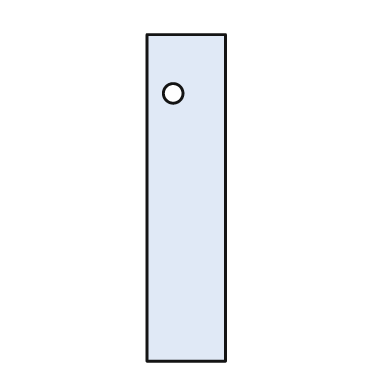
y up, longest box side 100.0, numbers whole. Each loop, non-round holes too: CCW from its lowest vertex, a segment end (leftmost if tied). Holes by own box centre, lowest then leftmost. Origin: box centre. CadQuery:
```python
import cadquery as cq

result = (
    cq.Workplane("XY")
    .moveTo(-12.0, -50.0)
    .lineTo(12.0, -50.0)
    .lineTo(12.0, 50.0)
    .lineTo(-12.0, 50.0)
    .close()
    .moveTo(-4.0, 32.0)
    .circle(3.0)
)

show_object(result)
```